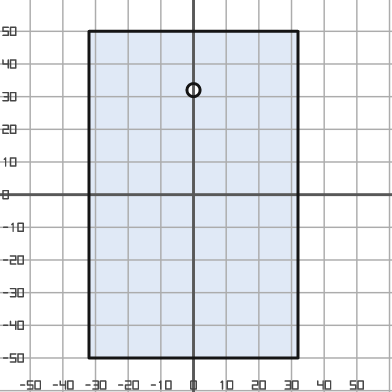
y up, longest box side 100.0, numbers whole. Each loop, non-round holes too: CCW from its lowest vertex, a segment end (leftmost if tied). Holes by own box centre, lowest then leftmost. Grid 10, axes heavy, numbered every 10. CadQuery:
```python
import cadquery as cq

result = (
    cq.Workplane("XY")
    .moveTo(-32.0, -50.0)
    .lineTo(32.0, -50.0)
    .lineTo(32.0, 50.0)
    .lineTo(-32.0, 50.0)
    .close()
    .moveTo(0.0, 32.0)
    .circle(2.0)
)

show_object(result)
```